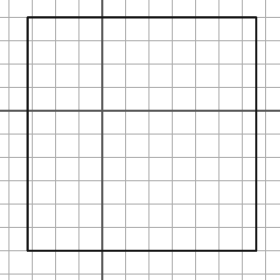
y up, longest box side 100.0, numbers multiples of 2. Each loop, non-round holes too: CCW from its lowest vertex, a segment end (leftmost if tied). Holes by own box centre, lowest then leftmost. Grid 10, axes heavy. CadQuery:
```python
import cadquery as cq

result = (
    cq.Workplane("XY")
    .moveTo(-32.0, -60.0)
    .lineTo(66.0, -60.0)
    .lineTo(66.0, 40.0)
    .lineTo(-32.0, 40.0)
    .close()
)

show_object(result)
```